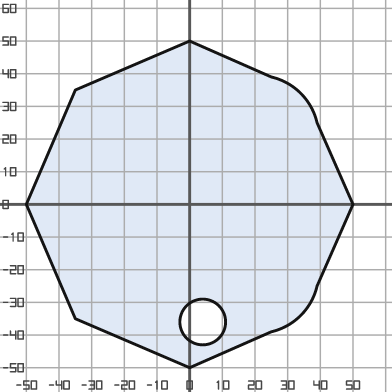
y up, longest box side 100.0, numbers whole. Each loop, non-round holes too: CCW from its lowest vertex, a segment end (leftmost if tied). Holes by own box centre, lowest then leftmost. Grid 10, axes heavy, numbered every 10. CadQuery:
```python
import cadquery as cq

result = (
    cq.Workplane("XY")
    .moveTo(0.0, -50.0)
    .lineTo(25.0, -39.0)
    .threePointArc((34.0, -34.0), (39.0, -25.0))
    .lineTo(50.0, 0.0)
    .lineTo(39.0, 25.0)
    .threePointArc((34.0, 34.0), (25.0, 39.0))
    .lineTo(0.0, 50.0)
    .lineTo(-35.0, 35.0)
    .lineTo(-50.0, 0.0)
    .lineTo(-35.0, -35.0)
    .close()
    .moveTo(4.0, -36.0)
    .circle(7.0)
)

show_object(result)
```